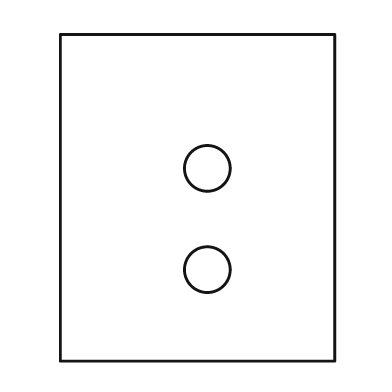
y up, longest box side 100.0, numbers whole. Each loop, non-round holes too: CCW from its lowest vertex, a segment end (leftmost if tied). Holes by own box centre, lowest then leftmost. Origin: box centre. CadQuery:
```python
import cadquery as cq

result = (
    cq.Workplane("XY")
    .moveTo(-42.0, -50.0)
    .lineTo(42.0, -50.0)
    .lineTo(42.0, 50.0)
    .lineTo(-42.0, 50.0)
    .close()
    .moveTo(3.0, -22.0)
    .circle(7.0)
    .moveTo(3.0, 9.0)
    .circle(7.0)
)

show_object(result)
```